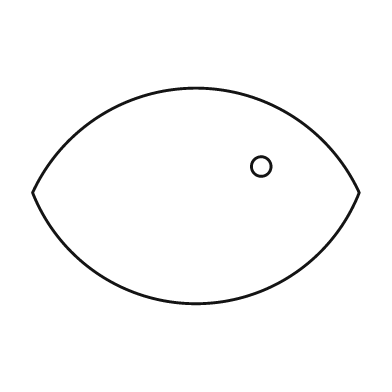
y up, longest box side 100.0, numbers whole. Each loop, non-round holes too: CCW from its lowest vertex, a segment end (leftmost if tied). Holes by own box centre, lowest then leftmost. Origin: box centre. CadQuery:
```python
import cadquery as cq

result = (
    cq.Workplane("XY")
    .moveTo(-50.0, 1.0)
    .threePointArc((0.0, -33.0), (50.0, 1.0))
    .threePointArc((0.0, 33.0), (-50.0, 1.0))
    .close()
    .moveTo(20.0, 9.0)
    .circle(3.0)
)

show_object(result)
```